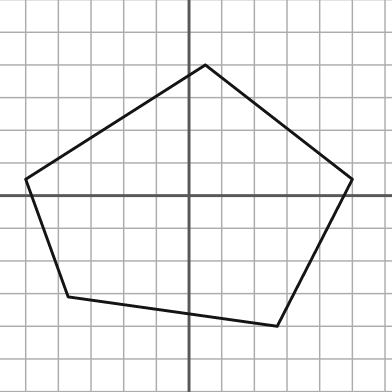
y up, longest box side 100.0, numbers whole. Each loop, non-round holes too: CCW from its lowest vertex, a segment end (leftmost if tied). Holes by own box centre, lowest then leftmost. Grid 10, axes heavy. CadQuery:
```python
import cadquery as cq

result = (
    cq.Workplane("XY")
    .moveTo(27.0, -40.0)
    .lineTo(50.0, 5.0)
    .lineTo(5.0, 40.0)
    .lineTo(-50.0, 5.0)
    .lineTo(-37.0, -31.0)
    .close()
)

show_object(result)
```